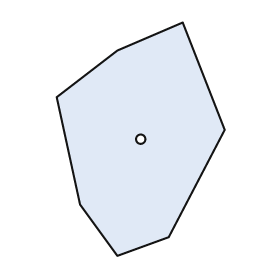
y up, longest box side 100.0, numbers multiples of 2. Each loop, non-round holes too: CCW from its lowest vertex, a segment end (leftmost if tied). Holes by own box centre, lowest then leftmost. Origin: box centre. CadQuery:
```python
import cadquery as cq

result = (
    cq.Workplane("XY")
    .moveTo(-10.0, -50.0)
    .lineTo(12.0, -42.0)
    .lineTo(36.0, 4.0)
    .lineTo(18.0, 50.0)
    .lineTo(-10.0, 38.0)
    .lineTo(-36.0, 18.0)
    .lineTo(-26.0, -28.0)
    .close()
    .moveTo(0.0, 0.0)
    .circle(2.0)
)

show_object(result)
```